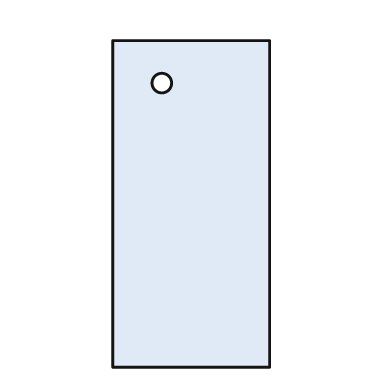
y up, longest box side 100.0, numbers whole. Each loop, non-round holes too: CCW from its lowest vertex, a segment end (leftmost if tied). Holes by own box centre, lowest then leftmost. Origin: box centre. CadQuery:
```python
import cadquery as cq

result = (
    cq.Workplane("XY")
    .moveTo(-24.0, -50.0)
    .lineTo(24.0, -50.0)
    .lineTo(24.0, 50.0)
    .lineTo(-24.0, 50.0)
    .close()
    .moveTo(-9.0, 37.0)
    .circle(3.0)
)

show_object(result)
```